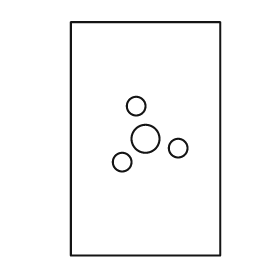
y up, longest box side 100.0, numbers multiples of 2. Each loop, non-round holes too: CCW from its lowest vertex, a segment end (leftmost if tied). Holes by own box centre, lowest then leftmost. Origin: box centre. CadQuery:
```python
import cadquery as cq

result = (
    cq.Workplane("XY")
    .moveTo(-32.0, -50.0)
    .lineTo(32.0, -50.0)
    .lineTo(32.0, 50.0)
    .lineTo(-32.0, 50.0)
    .close()
    .moveTo(-10.0, -10.0)
    .circle(4.0)
    .moveTo(14.0, -4.0)
    .circle(4.0)
    .moveTo(0.0, 0.0)
    .circle(6.0)
    .moveTo(-4.0, 14.0)
    .circle(4.0)
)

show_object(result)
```